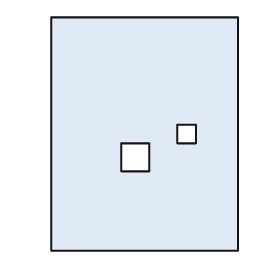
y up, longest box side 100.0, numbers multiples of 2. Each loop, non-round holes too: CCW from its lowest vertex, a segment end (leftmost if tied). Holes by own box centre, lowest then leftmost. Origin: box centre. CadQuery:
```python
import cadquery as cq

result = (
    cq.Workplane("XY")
    .moveTo(-40.0, -50.0)
    .lineTo(40.0, -50.0)
    .lineTo(40.0, 50.0)
    .lineTo(-40.0, 50.0)
    .close()
    .moveTo(-10.0, -16.0)
    .lineTo(2.0, -16.0)
    .lineTo(2.0, -4.0)
    .lineTo(-10.0, -4.0)
    .close()
    .moveTo(14.0, -4.0)
    .lineTo(22.0, -4.0)
    .lineTo(22.0, 4.0)
    .lineTo(14.0, 4.0)
    .close()
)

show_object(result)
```